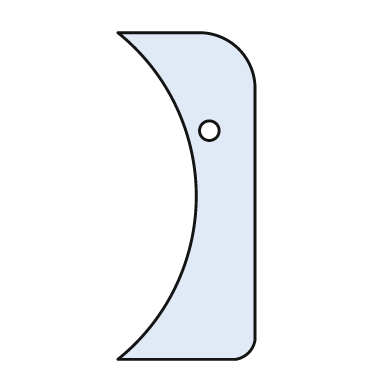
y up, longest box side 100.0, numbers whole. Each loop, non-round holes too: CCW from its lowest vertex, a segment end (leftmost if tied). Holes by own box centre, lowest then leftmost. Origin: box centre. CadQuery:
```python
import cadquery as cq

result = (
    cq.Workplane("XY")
    .moveTo(-21.0, -50.0)
    .lineTo(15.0, -50.0)
    .threePointArc((19.0, -48.0), (21.0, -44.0))
    .lineTo(21.0, 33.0)
    .threePointArc((16.0, 45.0), (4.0, 50.0))
    .lineTo(-21.0, 50.0)
    .threePointArc((3.0, 0.0), (-21.0, -50.0))
    .close()
    .moveTo(7.0, 20.0)
    .circle(3.0)
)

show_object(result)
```